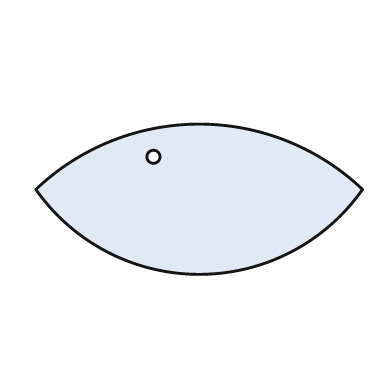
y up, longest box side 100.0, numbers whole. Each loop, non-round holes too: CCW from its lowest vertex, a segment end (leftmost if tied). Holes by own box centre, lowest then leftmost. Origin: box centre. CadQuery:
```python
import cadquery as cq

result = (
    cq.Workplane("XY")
    .moveTo(-50.0, 3.0)
    .threePointArc((0.0, -23.0), (50.0, 3.0))
    .threePointArc((0.0, 23.0), (-50.0, 3.0))
    .close()
    .moveTo(-14.0, 13.0)
    .circle(2.0)
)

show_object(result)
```